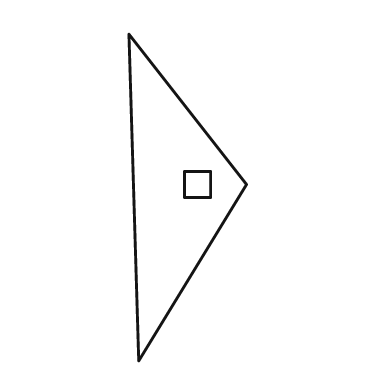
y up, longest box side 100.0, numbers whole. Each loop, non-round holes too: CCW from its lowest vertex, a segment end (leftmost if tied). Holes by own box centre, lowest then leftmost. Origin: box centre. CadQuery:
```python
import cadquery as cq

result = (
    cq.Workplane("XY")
    .moveTo(-15.0, -50.0)
    .lineTo(18.0, 4.0)
    .lineTo(-18.0, 50.0)
    .close()
    .moveTo(-1.0, 0.0)
    .lineTo(7.0, 0.0)
    .lineTo(7.0, 8.0)
    .lineTo(-1.0, 8.0)
    .close()
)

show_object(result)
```